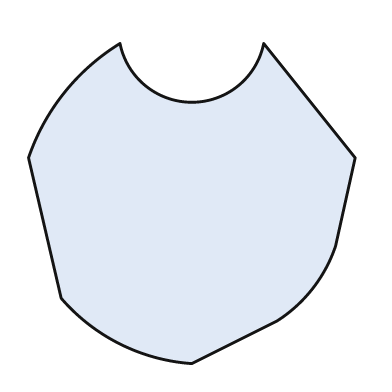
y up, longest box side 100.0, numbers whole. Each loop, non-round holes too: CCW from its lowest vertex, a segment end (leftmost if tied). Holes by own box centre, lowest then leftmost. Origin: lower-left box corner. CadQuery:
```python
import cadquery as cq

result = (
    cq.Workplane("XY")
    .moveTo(50.0, 0.0)
    .lineTo(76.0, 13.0)
    .threePointArc((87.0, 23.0), (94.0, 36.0))
    .lineTo(100.0, 63.0)
    .lineTo(72.0, 98.0)
    .threePointArc((50.0, 80.0), (28.0, 98.0))
    .threePointArc((11.0, 83.0), (0.0, 63.0))
    .lineTo(10.0, 20.0)
    .threePointArc((28.0, 6.0), (50.0, 0.0))
    .close()
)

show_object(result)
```